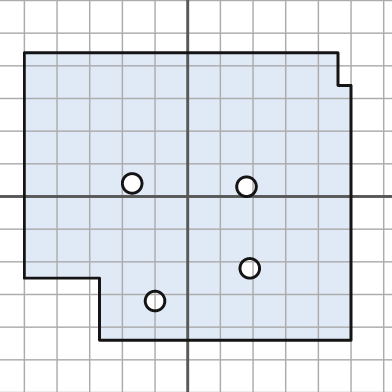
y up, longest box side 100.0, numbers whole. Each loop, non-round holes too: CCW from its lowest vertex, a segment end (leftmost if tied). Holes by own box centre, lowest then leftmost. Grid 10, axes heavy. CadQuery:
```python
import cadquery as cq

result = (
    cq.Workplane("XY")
    .moveTo(-27.0, -44.0)
    .lineTo(50.0, -44.0)
    .lineTo(50.0, 34.0)
    .lineTo(46.0, 34.0)
    .lineTo(46.0, 44.0)
    .lineTo(-50.0, 44.0)
    .lineTo(-50.0, -25.0)
    .lineTo(-27.0, -25.0)
    .close()
    .moveTo(-10.0, -32.0)
    .circle(3.0)
    .moveTo(19.0, -22.0)
    .circle(3.0)
    .moveTo(18.0, 3.0)
    .circle(3.0)
    .moveTo(-17.0, 4.0)
    .circle(3.0)
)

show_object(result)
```